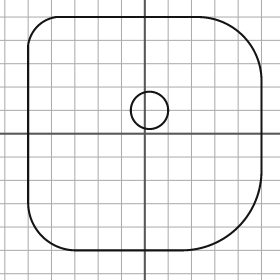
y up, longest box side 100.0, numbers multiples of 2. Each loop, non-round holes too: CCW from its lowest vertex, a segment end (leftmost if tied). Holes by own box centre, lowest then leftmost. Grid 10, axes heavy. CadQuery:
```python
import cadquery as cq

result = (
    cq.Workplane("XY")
    .moveTo(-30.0, -50.0)
    .lineTo(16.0, -50.0)
    .threePointArc((40.0, -40.0), (50.0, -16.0))
    .lineTo(50.0, 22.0)
    .threePointArc((42.0, 42.0), (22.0, 50.0))
    .lineTo(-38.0, 50.0)
    .threePointArc((-46.0, 46.0), (-50.0, 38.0))
    .lineTo(-50.0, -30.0)
    .threePointArc((-44.0, -44.0), (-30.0, -50.0))
    .close()
    .moveTo(2.0, 10.0)
    .circle(8.0)
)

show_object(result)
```